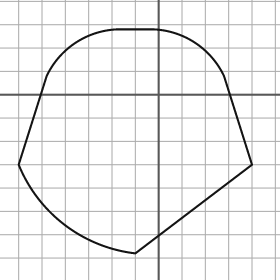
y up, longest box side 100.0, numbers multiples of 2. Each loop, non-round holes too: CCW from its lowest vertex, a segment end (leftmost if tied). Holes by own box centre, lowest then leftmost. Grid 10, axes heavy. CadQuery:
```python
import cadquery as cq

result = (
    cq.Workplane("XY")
    .moveTo(-10.0, -68.0)
    .lineTo(40.0, -30.0)
    .lineTo(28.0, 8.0)
    .threePointArc((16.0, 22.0), (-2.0, 28.0))
    .lineTo(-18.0, 28.0)
    .threePointArc((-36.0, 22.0), (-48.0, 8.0))
    .lineTo(-60.0, -30.0)
    .threePointArc((-40.0, -56.0), (-10.0, -68.0))
    .close()
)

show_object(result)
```